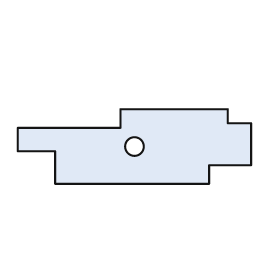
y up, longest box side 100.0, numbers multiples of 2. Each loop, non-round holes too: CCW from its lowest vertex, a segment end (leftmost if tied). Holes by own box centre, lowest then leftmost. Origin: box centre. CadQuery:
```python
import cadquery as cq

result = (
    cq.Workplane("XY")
    .moveTo(-34.0, -16.0)
    .lineTo(32.0, -16.0)
    .lineTo(32.0, -8.0)
    .lineTo(50.0, -8.0)
    .lineTo(50.0, 10.0)
    .lineTo(40.0, 10.0)
    .lineTo(40.0, 16.0)
    .lineTo(-6.0, 16.0)
    .lineTo(-6.0, 8.0)
    .lineTo(-50.0, 8.0)
    .lineTo(-50.0, -2.0)
    .lineTo(-34.0, -2.0)
    .close()
    .moveTo(0.0, 0.0)
    .circle(4.0)
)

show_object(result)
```